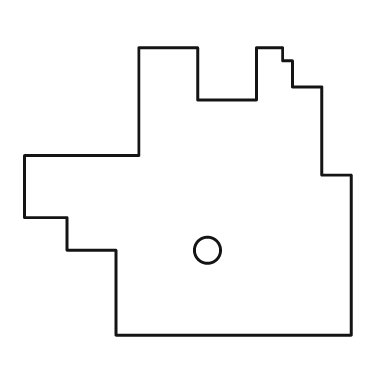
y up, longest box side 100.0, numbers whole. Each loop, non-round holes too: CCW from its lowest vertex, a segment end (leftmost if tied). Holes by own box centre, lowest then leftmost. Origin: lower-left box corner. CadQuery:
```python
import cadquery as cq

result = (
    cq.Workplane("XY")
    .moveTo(28.0, 0.0)
    .lineTo(100.0, 0.0)
    .lineTo(100.0, 49.0)
    .lineTo(91.0, 49.0)
    .lineTo(91.0, 76.0)
    .lineTo(82.0, 76.0)
    .lineTo(82.0, 84.0)
    .lineTo(79.0, 84.0)
    .lineTo(79.0, 88.0)
    .lineTo(71.0, 88.0)
    .lineTo(71.0, 72.0)
    .lineTo(53.0, 72.0)
    .lineTo(53.0, 88.0)
    .lineTo(35.0, 88.0)
    .lineTo(35.0, 55.0)
    .lineTo(0.0, 55.0)
    .lineTo(0.0, 36.0)
    .lineTo(13.0, 36.0)
    .lineTo(13.0, 26.0)
    .lineTo(28.0, 26.0)
    .close()
    .moveTo(56.0, 26.0)
    .circle(4.0)
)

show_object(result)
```